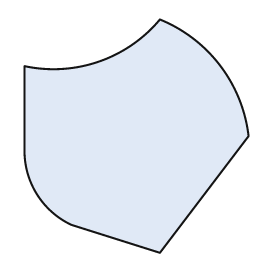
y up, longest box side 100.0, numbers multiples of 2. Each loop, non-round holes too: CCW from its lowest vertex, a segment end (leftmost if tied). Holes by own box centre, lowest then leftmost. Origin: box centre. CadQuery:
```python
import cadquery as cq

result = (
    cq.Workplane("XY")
    .moveTo(10.0, -50.0)
    .lineTo(48.0, 0.0)
    .threePointArc((36.0, 30.0), (10.0, 50.0))
    .threePointArc((-16.0, 32.0), (-48.0, 30.0))
    .lineTo(-48.0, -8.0)
    .threePointArc((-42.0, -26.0), (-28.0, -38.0))
    .close()
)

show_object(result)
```